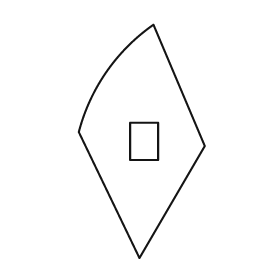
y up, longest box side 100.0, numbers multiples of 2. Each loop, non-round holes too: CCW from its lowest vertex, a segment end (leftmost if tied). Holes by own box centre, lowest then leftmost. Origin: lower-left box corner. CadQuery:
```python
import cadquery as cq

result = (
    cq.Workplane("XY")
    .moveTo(26.0, 0.0)
    .lineTo(54.0, 48.0)
    .lineTo(32.0, 100.0)
    .threePointArc((12.0, 80.0), (0.0, 54.0))
    .close()
    .moveTo(22.0, 42.0)
    .lineTo(34.0, 42.0)
    .lineTo(34.0, 58.0)
    .lineTo(22.0, 58.0)
    .close()
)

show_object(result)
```